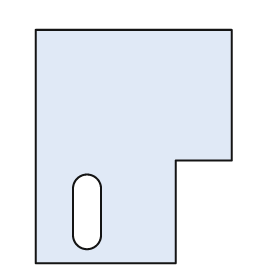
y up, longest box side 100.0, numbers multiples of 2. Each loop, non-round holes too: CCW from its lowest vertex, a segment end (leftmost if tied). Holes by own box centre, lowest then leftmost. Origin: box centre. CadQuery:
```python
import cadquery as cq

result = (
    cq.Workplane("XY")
    .moveTo(-42.0, -50.0)
    .lineTo(18.0, -50.0)
    .lineTo(18.0, -6.0)
    .lineTo(42.0, -6.0)
    .lineTo(42.0, 50.0)
    .lineTo(-42.0, 50.0)
    .close()
    .moveTo(-26.0, -38.0)
    .threePointArc((-20.0, -44.0), (-14.0, -38.0))
    .lineTo(-14.0, -18.0)
    .threePointArc((-20.0, -12.0), (-26.0, -18.0))
    .close()
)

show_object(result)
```